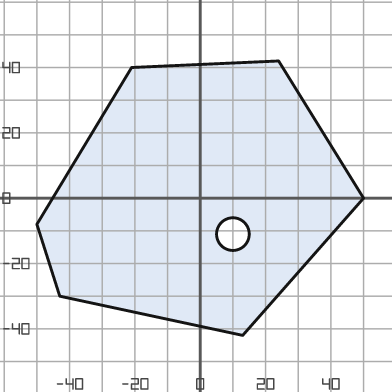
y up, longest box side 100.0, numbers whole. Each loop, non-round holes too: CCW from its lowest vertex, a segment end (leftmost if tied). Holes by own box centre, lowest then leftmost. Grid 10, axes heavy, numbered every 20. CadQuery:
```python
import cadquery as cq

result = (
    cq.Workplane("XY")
    .moveTo(13.0, -42.0)
    .lineTo(50.0, 0.0)
    .lineTo(24.0, 42.0)
    .lineTo(-21.0, 40.0)
    .lineTo(-50.0, -8.0)
    .lineTo(-43.0, -30.0)
    .close()
    .moveTo(10.0, -11.0)
    .circle(5.0)
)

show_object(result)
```